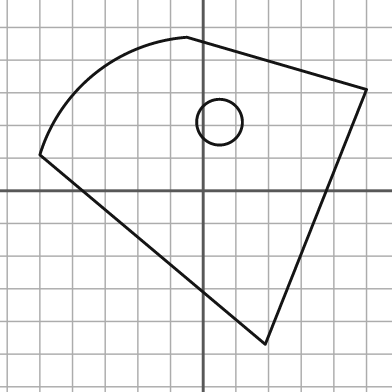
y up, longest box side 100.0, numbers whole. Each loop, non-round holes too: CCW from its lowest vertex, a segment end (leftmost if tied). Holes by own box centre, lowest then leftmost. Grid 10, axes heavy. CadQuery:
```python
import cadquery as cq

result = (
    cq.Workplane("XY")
    .moveTo(19.0, -47.0)
    .lineTo(50.0, 31.0)
    .lineTo(-5.0, 47.0)
    .threePointArc((-33.0, 36.0), (-50.0, 11.0))
    .close()
    .moveTo(5.0, 21.0)
    .circle(7.0)
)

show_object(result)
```